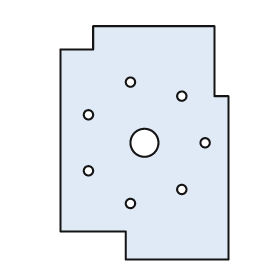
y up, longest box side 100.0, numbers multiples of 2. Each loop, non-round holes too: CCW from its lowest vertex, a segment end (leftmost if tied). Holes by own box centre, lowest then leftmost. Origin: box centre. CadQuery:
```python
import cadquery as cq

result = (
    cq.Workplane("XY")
    .moveTo(-8.0, -50.0)
    .lineTo(36.0, -50.0)
    .lineTo(36.0, 20.0)
    .lineTo(30.0, 20.0)
    .lineTo(30.0, 50.0)
    .lineTo(-22.0, 50.0)
    .lineTo(-22.0, 40.0)
    .lineTo(-36.0, 40.0)
    .lineTo(-36.0, -38.0)
    .lineTo(-8.0, -38.0)
    .close()
    .moveTo(-6.0, -26.0)
    .circle(2.0)
    .moveTo(16.0, -20.0)
    .circle(2.0)
    .moveTo(-24.0, -12.0)
    .circle(2.0)
    .moveTo(0.0, 0.0)
    .circle(6.0)
    .moveTo(26.0, 0.0)
    .circle(2.0)
    .moveTo(-24.0, 12.0)
    .circle(2.0)
    .moveTo(16.0, 20.0)
    .circle(2.0)
    .moveTo(-6.0, 26.0)
    .circle(2.0)
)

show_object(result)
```